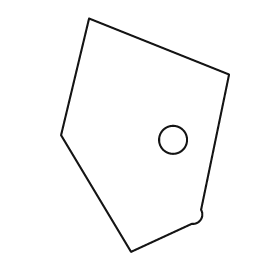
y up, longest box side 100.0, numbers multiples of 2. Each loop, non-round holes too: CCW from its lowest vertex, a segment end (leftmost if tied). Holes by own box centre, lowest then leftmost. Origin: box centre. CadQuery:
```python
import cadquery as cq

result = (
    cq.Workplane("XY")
    .moveTo(-6.0, -50.0)
    .lineTo(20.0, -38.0)
    .threePointArc((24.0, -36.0), (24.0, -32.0))
    .lineTo(36.0, 26.0)
    .lineTo(-24.0, 50.0)
    .lineTo(-36.0, 0.0)
    .close()
    .moveTo(12.0, -2.0)
    .circle(6.0)
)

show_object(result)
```